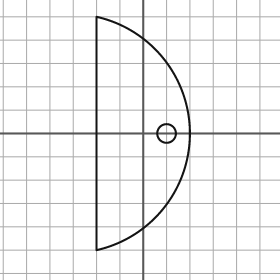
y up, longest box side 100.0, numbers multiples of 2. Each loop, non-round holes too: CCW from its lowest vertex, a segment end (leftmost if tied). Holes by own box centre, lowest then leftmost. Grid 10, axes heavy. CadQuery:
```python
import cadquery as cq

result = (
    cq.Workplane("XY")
    .moveTo(-20.0, -50.0)
    .threePointArc((20.0, 0.0), (-20.0, 50.0))
    .close()
    .moveTo(10.0, 0.0)
    .circle(4.0)
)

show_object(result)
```